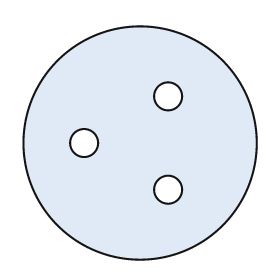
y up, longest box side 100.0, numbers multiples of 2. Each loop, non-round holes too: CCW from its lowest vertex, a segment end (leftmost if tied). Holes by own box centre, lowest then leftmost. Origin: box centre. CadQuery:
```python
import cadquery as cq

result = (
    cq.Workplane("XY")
    .moveTo(0.0, 0.0)
    .circle(50.0)
    .moveTo(12.0, -20.0)
    .circle(6.0)
    .moveTo(-24.0, 0.0)
    .circle(6.0)
    .moveTo(12.0, 20.0)
    .circle(6.0)
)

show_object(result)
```